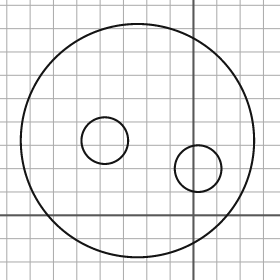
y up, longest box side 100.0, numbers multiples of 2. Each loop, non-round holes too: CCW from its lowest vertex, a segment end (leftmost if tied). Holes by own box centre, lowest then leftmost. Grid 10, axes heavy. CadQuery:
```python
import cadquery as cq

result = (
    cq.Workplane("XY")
    .moveTo(-24.0, 32.0)
    .circle(50.0)
    .moveTo(2.0, 20.0)
    .circle(10.0)
    .moveTo(-38.0, 32.0)
    .circle(10.0)
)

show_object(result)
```